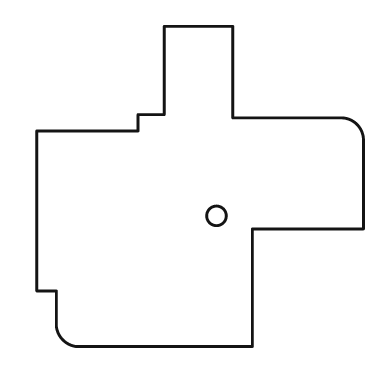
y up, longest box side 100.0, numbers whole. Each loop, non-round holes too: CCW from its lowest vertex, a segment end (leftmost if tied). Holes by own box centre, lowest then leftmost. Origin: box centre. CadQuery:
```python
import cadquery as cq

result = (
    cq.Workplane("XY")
    .moveTo(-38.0, -49.0)
    .lineTo(16.0, -49.0)
    .lineTo(16.0, -13.0)
    .lineTo(50.0, -13.0)
    .lineTo(50.0, 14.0)
    .threePointArc((48.0, 19.0), (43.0, 21.0))
    .lineTo(10.0, 21.0)
    .lineTo(10.0, 49.0)
    .lineTo(-11.0, 49.0)
    .lineTo(-11.0, 22.0)
    .lineTo(-19.0, 22.0)
    .lineTo(-19.0, 17.0)
    .lineTo(-50.0, 17.0)
    .lineTo(-50.0, -32.0)
    .lineTo(-44.0, -32.0)
    .lineTo(-44.0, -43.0)
    .threePointArc((-42.0, -47.0), (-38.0, -49.0))
    .close()
    .moveTo(5.0, -9.0)
    .circle(3.0)
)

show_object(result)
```